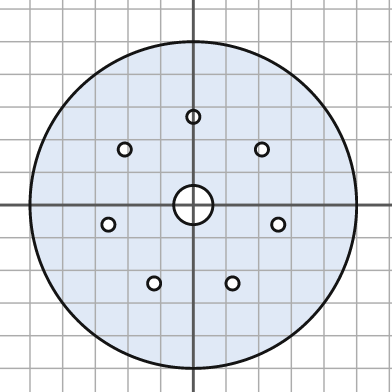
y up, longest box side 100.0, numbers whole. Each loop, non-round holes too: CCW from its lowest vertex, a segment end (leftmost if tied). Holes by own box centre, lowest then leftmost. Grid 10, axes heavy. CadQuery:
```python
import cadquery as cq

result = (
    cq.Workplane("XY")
    .moveTo(0.0, 0.0)
    .circle(50.0)
    .moveTo(-12.0, -24.0)
    .circle(2.0)
    .moveTo(12.0, -24.0)
    .circle(2.0)
    .moveTo(-26.0, -6.0)
    .circle(2.0)
    .moveTo(26.0, -6.0)
    .circle(2.0)
    .moveTo(0.0, 0.0)
    .circle(6.0)
    .moveTo(-21.0, 17.0)
    .circle(2.0)
    .moveTo(21.0, 17.0)
    .circle(2.0)
    .moveTo(0.0, 27.0)
    .circle(2.0)
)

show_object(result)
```